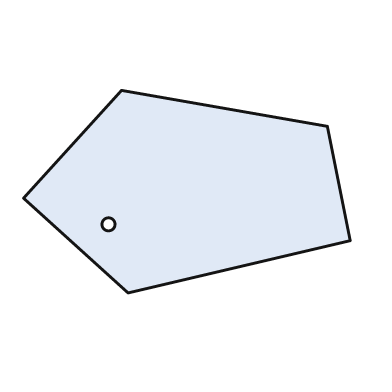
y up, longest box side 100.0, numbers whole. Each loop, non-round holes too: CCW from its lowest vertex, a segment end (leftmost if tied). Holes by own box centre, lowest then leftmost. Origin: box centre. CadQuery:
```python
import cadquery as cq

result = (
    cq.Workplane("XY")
    .moveTo(-18.0, -31.0)
    .lineTo(50.0, -15.0)
    .lineTo(43.0, 20.0)
    .lineTo(-20.0, 31.0)
    .lineTo(-50.0, -2.0)
    .close()
    .moveTo(-24.0, -10.0)
    .circle(2.0)
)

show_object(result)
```